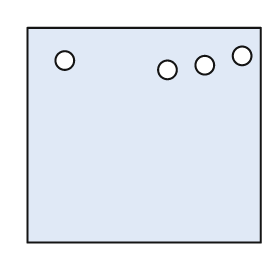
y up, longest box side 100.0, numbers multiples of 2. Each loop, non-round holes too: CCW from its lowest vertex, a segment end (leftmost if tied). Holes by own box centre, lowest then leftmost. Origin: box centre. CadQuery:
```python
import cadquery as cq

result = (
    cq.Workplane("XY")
    .moveTo(-50.0, -46.0)
    .lineTo(50.0, -46.0)
    .lineTo(50.0, 46.0)
    .lineTo(-50.0, 46.0)
    .close()
    .moveTo(10.0, 28.0)
    .circle(4.0)
    .moveTo(26.0, 30.0)
    .circle(4.0)
    .moveTo(-34.0, 32.0)
    .circle(4.0)
    .moveTo(42.0, 34.0)
    .circle(4.0)
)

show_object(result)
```